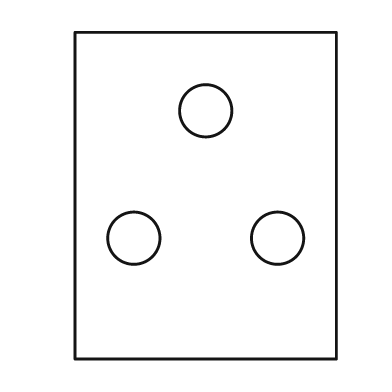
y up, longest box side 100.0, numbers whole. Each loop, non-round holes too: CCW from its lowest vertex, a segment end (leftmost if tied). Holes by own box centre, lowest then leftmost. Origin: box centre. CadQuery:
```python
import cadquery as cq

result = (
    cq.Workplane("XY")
    .moveTo(-40.0, -50.0)
    .lineTo(40.0, -50.0)
    .lineTo(40.0, 50.0)
    .lineTo(-40.0, 50.0)
    .close()
    .moveTo(-22.0, -13.0)
    .circle(8.0)
    .moveTo(22.0, -13.0)
    .circle(8.0)
    .moveTo(0.0, 26.0)
    .circle(8.0)
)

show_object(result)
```